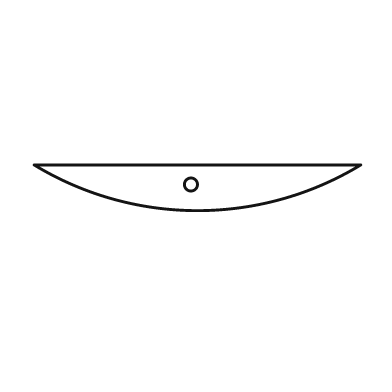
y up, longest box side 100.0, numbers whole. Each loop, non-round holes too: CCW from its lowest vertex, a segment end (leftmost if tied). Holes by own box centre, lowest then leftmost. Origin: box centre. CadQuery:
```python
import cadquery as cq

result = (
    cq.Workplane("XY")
    .moveTo(-50.0, 7.0)
    .threePointArc((0.0, -7.0), (50.0, 7.0))
    .close()
    .moveTo(-2.0, 1.0)
    .circle(2.0)
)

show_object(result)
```